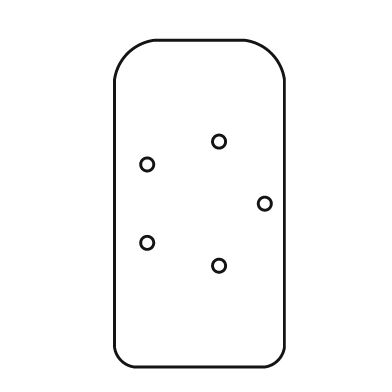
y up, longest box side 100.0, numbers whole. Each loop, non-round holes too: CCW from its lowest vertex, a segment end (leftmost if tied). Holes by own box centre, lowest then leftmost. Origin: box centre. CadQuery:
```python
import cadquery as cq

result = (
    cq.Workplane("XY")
    .moveTo(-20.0, -50.0)
    .lineTo(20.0, -50.0)
    .threePointArc((24.0, -48.0), (26.0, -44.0))
    .lineTo(26.0, 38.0)
    .threePointArc((22.0, 46.0), (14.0, 50.0))
    .lineTo(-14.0, 50.0)
    .threePointArc((-22.0, 46.0), (-26.0, 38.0))
    .lineTo(-26.0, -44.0)
    .threePointArc((-24.0, -48.0), (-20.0, -50.0))
    .close()
    .moveTo(6.0, -19.0)
    .circle(2.0)
    .moveTo(-16.0, -12.0)
    .circle(2.0)
    .moveTo(20.0, 0.0)
    .circle(2.0)
    .moveTo(-16.0, 12.0)
    .circle(2.0)
    .moveTo(6.0, 19.0)
    .circle(2.0)
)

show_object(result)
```